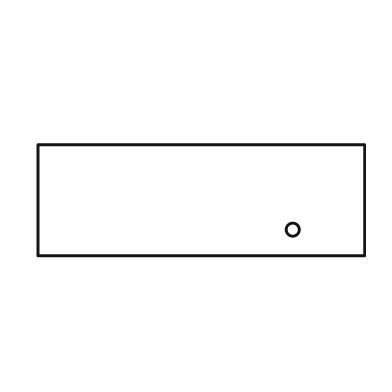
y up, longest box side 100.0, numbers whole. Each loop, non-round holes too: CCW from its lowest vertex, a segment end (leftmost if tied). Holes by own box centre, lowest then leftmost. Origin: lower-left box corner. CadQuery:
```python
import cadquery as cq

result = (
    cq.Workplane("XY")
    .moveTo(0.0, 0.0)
    .lineTo(100.0, 0.0)
    .lineTo(100.0, 34.0)
    .lineTo(0.0, 34.0)
    .close()
    .moveTo(78.0, 8.0)
    .circle(2.0)
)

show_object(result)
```